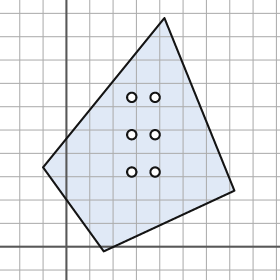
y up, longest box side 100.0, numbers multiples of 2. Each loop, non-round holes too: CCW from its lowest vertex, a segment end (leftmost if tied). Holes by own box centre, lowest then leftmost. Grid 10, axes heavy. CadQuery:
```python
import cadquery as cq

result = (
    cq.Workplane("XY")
    .moveTo(16.0, -2.0)
    .lineTo(72.0, 24.0)
    .lineTo(42.0, 98.0)
    .lineTo(-10.0, 34.0)
    .close()
    .moveTo(28.0, 32.0)
    .circle(2.0)
    .moveTo(38.0, 32.0)
    .circle(2.0)
    .moveTo(28.0, 48.0)
    .circle(2.0)
    .moveTo(38.0, 48.0)
    .circle(2.0)
    .moveTo(28.0, 64.0)
    .circle(2.0)
    .moveTo(38.0, 64.0)
    .circle(2.0)
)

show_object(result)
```